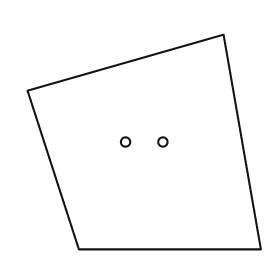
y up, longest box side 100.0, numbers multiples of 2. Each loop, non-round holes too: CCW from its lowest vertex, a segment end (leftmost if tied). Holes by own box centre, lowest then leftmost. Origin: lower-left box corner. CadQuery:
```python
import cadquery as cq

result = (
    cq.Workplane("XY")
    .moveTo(22.0, 0.0)
    .lineTo(100.0, 0.0)
    .lineTo(84.0, 92.0)
    .lineTo(0.0, 68.0)
    .close()
    .moveTo(42.0, 46.0)
    .circle(2.0)
    .moveTo(58.0, 46.0)
    .circle(2.0)
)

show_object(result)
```